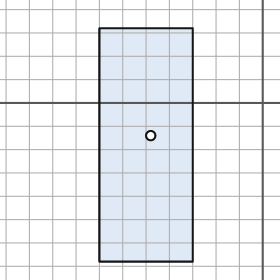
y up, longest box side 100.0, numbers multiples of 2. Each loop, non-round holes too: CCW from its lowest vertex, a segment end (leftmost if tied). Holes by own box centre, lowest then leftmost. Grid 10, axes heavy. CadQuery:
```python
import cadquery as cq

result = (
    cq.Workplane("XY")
    .moveTo(-70.0, -68.0)
    .lineTo(-30.0, -68.0)
    .lineTo(-30.0, 32.0)
    .lineTo(-70.0, 32.0)
    .close()
    .moveTo(-48.0, -14.0)
    .circle(2.0)
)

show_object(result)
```